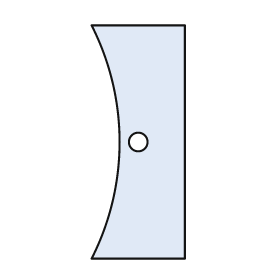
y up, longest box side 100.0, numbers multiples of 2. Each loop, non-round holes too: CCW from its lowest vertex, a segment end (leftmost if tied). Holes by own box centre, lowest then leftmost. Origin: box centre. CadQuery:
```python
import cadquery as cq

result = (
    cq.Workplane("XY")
    .moveTo(-20.0, -50.0)
    .lineTo(20.0, -50.0)
    .lineTo(20.0, 50.0)
    .lineTo(-20.0, 50.0)
    .threePointArc((-8.0, 0.0), (-20.0, -50.0))
    .close()
    .moveTo(0.0, 0.0)
    .circle(4.0)
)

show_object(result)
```